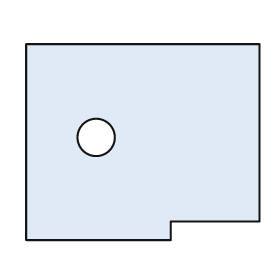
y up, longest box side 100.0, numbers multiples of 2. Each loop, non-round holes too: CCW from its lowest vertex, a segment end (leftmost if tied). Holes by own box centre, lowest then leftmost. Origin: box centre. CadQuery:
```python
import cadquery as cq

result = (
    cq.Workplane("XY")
    .moveTo(-50.0, -42.0)
    .lineTo(12.0, -42.0)
    .lineTo(12.0, -34.0)
    .lineTo(50.0, -34.0)
    .lineTo(50.0, 42.0)
    .lineTo(-50.0, 42.0)
    .close()
    .moveTo(-20.0, 2.0)
    .circle(8.0)
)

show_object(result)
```